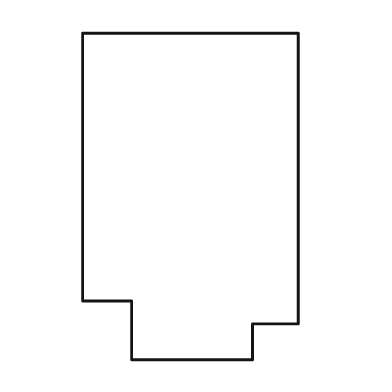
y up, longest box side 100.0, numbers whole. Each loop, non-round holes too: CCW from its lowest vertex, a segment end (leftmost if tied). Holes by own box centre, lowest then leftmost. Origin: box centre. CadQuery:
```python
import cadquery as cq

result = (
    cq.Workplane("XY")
    .moveTo(-18.0, -50.0)
    .lineTo(19.0, -50.0)
    .lineTo(19.0, -39.0)
    .lineTo(33.0, -39.0)
    .lineTo(33.0, 50.0)
    .lineTo(-33.0, 50.0)
    .lineTo(-33.0, -32.0)
    .lineTo(-18.0, -32.0)
    .close()
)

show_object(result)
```